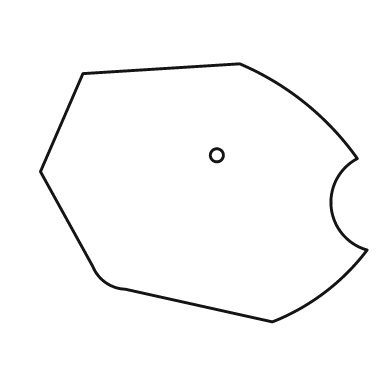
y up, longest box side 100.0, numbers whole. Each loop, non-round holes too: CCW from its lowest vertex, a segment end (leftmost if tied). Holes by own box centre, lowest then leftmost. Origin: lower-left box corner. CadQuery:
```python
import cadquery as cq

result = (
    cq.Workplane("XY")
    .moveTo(71.0, 0.0)
    .threePointArc((87.0, 9.0), (100.0, 22.0))
    .threePointArc((89.0, 35.0), (97.0, 50.0))
    .threePointArc((81.0, 67.0), (61.0, 79.0))
    .lineTo(13.0, 76.0)
    .lineTo(0.0, 46.0)
    .lineTo(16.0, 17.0)
    .threePointArc((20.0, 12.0), (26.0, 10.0))
    .close()
    .moveTo(54.0, 51.0)
    .circle(2.0)
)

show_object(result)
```